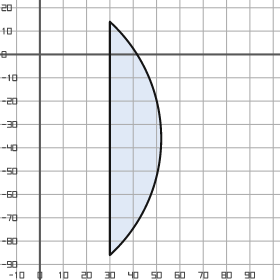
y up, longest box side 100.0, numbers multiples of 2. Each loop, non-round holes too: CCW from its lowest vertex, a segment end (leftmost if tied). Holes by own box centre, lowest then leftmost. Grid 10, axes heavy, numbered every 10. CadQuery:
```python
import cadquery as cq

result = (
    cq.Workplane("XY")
    .moveTo(30.0, -86.0)
    .threePointArc((52.0, -36.0), (30.0, 14.0))
    .close()
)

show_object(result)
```